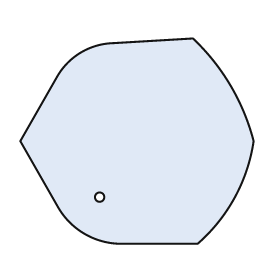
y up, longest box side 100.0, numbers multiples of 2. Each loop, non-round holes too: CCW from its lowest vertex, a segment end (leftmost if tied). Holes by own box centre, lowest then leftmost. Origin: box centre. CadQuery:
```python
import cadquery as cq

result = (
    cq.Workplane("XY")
    .moveTo(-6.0, -44.0)
    .lineTo(26.0, -44.0)
    .threePointArc((42.0, -24.0), (50.0, 0.0))
    .threePointArc((40.0, 24.0), (24.0, 44.0))
    .lineTo(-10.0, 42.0)
    .threePointArc((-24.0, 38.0), (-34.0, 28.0))
    .lineTo(-50.0, 0.0)
    .lineTo(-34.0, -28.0)
    .threePointArc((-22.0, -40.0), (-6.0, -44.0))
    .close()
    .moveTo(-16.0, -24.0)
    .circle(2.0)
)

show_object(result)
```